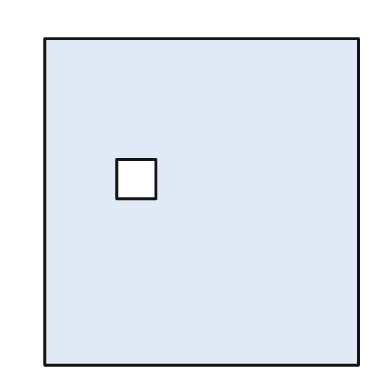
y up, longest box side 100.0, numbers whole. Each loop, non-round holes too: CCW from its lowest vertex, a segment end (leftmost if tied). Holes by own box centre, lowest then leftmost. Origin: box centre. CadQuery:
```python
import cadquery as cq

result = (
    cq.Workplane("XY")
    .moveTo(-48.0, -50.0)
    .lineTo(48.0, -50.0)
    .lineTo(48.0, 50.0)
    .lineTo(-48.0, 50.0)
    .close()
    .moveTo(-26.0, 1.0)
    .lineTo(-14.0, 1.0)
    .lineTo(-14.0, 13.0)
    .lineTo(-26.0, 13.0)
    .close()
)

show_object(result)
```